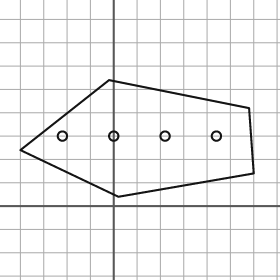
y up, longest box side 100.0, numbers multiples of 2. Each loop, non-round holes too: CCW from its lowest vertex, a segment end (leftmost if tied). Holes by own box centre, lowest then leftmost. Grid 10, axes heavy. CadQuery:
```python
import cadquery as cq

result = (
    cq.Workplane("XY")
    .moveTo(2.0, 4.0)
    .lineTo(60.0, 14.0)
    .lineTo(58.0, 42.0)
    .lineTo(-2.0, 54.0)
    .lineTo(-40.0, 24.0)
    .close()
    .moveTo(-22.0, 30.0)
    .circle(2.0)
    .moveTo(0.0, 30.0)
    .circle(2.0)
    .moveTo(22.0, 30.0)
    .circle(2.0)
    .moveTo(44.0, 30.0)
    .circle(2.0)
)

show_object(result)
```